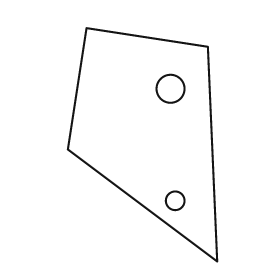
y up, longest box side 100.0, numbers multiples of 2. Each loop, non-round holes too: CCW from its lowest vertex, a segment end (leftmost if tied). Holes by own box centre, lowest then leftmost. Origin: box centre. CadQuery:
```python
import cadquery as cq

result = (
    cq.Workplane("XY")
    .moveTo(32.0, -50.0)
    .lineTo(28.0, 42.0)
    .lineTo(-24.0, 50.0)
    .lineTo(-32.0, -2.0)
    .close()
    .moveTo(14.0, -24.0)
    .circle(4.0)
    .moveTo(12.0, 24.0)
    .circle(6.0)
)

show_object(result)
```